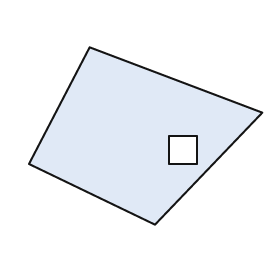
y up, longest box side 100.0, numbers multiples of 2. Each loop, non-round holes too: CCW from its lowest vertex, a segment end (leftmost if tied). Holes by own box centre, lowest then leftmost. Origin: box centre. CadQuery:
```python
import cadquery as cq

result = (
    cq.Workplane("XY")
    .moveTo(4.0, -38.0)
    .lineTo(50.0, 10.0)
    .lineTo(-24.0, 38.0)
    .lineTo(-50.0, -12.0)
    .close()
    .moveTo(10.0, -12.0)
    .lineTo(22.0, -12.0)
    .lineTo(22.0, 0.0)
    .lineTo(10.0, 0.0)
    .close()
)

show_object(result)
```